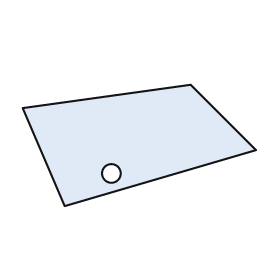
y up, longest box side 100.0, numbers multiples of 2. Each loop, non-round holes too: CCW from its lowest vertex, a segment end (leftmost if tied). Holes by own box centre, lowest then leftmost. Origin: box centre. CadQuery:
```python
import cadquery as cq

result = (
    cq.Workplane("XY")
    .moveTo(-32.0, -26.0)
    .lineTo(50.0, -2.0)
    .lineTo(22.0, 26.0)
    .lineTo(-50.0, 16.0)
    .close()
    .moveTo(-12.0, -12.0)
    .circle(4.0)
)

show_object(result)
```